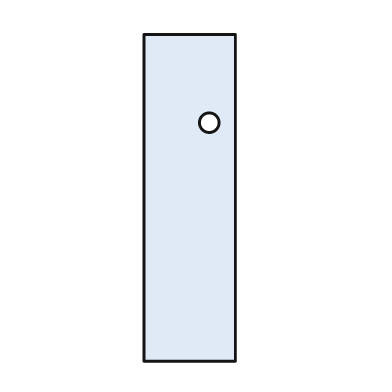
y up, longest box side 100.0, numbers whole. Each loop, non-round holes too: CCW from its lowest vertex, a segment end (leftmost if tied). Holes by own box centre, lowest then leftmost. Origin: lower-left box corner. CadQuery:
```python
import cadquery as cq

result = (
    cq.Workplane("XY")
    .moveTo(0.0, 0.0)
    .lineTo(28.0, 0.0)
    .lineTo(28.0, 100.0)
    .lineTo(0.0, 100.0)
    .close()
    .moveTo(20.0, 73.0)
    .circle(3.0)
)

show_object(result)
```